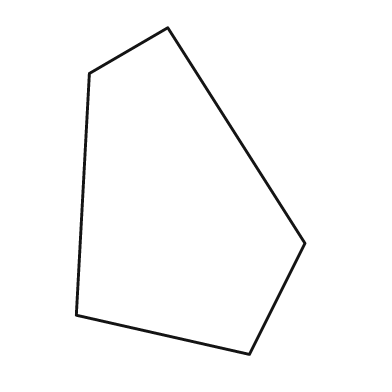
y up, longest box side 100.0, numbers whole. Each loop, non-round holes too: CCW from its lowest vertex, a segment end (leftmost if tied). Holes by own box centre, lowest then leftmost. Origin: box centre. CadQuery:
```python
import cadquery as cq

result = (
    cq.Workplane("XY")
    .moveTo(18.0, -50.0)
    .lineTo(35.0, -16.0)
    .lineTo(-7.0, 50.0)
    .lineTo(-31.0, 36.0)
    .lineTo(-35.0, -38.0)
    .close()
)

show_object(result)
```